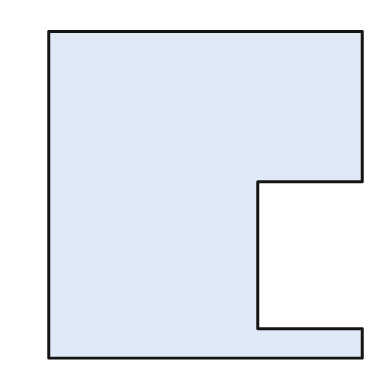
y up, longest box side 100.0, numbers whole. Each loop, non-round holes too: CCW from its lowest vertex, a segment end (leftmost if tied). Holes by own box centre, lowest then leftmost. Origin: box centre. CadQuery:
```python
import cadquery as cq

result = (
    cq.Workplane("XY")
    .moveTo(-48.0, -50.0)
    .lineTo(48.0, -50.0)
    .lineTo(48.0, -41.0)
    .lineTo(16.0, -41.0)
    .lineTo(16.0, 4.0)
    .lineTo(48.0, 4.0)
    .lineTo(48.0, 50.0)
    .lineTo(-48.0, 50.0)
    .close()
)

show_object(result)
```